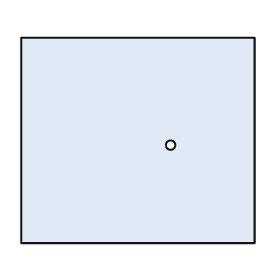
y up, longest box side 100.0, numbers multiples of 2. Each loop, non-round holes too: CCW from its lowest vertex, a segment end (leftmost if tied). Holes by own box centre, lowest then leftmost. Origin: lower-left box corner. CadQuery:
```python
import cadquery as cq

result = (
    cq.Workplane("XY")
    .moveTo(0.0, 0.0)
    .lineTo(100.0, 0.0)
    .lineTo(100.0, 88.0)
    .lineTo(0.0, 88.0)
    .close()
    .moveTo(64.0, 42.0)
    .circle(2.0)
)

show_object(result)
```